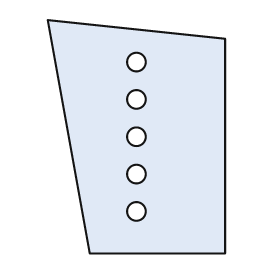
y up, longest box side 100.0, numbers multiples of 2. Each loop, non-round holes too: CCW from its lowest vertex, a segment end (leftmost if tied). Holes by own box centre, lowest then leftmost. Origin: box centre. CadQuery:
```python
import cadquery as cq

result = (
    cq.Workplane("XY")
    .moveTo(-20.0, -50.0)
    .lineTo(38.0, -50.0)
    .lineTo(38.0, 42.0)
    .lineTo(-38.0, 50.0)
    .close()
    .moveTo(0.0, -32.0)
    .circle(4.0)
    .moveTo(0.0, -16.0)
    .circle(4.0)
    .moveTo(0.0, 0.0)
    .circle(4.0)
    .moveTo(0.0, 16.0)
    .circle(4.0)
    .moveTo(0.0, 32.0)
    .circle(4.0)
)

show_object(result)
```